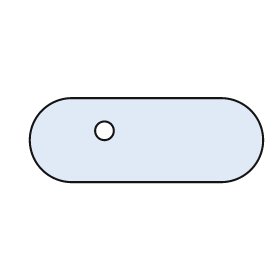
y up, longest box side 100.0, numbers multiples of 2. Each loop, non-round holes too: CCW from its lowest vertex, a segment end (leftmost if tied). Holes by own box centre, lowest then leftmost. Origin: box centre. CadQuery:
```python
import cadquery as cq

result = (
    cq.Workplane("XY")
    .moveTo(-32.0, -18.0)
    .lineTo(32.0, -18.0)
    .threePointArc((50.0, 0.0), (32.0, 18.0))
    .lineTo(-32.0, 18.0)
    .threePointArc((-50.0, 0.0), (-32.0, -18.0))
    .close()
    .moveTo(-18.0, 4.0)
    .circle(4.0)
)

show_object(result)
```